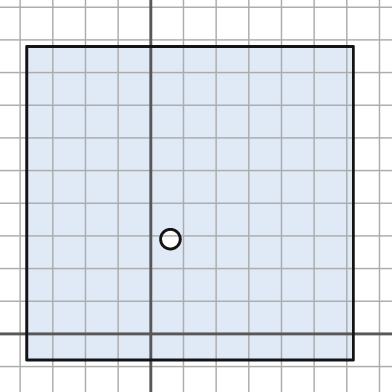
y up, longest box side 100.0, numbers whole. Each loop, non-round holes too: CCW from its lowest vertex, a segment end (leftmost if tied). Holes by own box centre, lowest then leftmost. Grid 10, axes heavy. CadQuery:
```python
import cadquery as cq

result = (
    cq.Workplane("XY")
    .moveTo(-38.0, -8.0)
    .lineTo(62.0, -8.0)
    .lineTo(62.0, 88.0)
    .lineTo(-38.0, 88.0)
    .close()
    .moveTo(6.0, 29.0)
    .circle(3.0)
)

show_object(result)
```